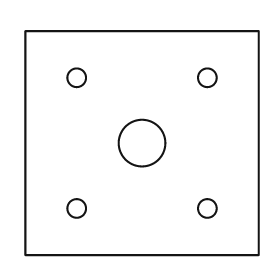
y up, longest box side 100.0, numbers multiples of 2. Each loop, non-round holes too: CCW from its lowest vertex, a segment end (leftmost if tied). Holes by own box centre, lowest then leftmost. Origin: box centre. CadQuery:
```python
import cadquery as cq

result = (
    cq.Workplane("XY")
    .moveTo(-50.0, -48.0)
    .lineTo(50.0, -48.0)
    .lineTo(50.0, 48.0)
    .lineTo(-50.0, 48.0)
    .close()
    .moveTo(-28.0, -28.0)
    .circle(4.0)
    .moveTo(28.0, -28.0)
    .circle(4.0)
    .moveTo(0.0, 0.0)
    .circle(10.0)
    .moveTo(-28.0, 28.0)
    .circle(4.0)
    .moveTo(28.0, 28.0)
    .circle(4.0)
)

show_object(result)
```